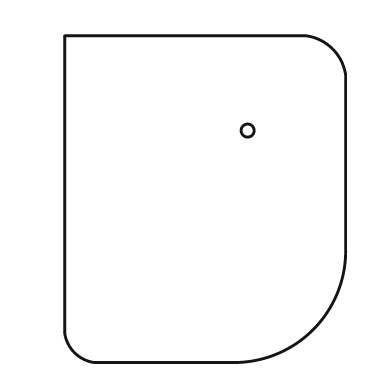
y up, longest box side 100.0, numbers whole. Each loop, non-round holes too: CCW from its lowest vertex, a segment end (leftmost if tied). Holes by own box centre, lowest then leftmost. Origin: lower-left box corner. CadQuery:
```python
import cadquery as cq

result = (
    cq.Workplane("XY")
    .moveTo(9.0, 0.0)
    .lineTo(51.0, 0.0)
    .threePointArc((76.0, 10.0), (86.0, 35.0))
    .lineTo(86.0, 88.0)
    .threePointArc((82.0, 96.0), (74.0, 100.0))
    .lineTo(0.0, 100.0)
    .lineTo(0.0, 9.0)
    .threePointArc((3.0, 3.0), (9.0, 0.0))
    .close()
    .moveTo(56.0, 71.0)
    .circle(2.0)
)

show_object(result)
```